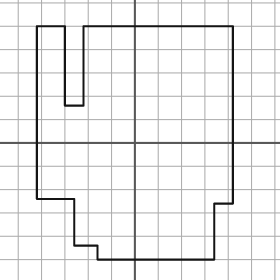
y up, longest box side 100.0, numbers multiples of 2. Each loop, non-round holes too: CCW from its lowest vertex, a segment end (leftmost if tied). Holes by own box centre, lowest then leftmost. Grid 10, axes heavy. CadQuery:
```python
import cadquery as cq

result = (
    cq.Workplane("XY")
    .moveTo(-16.0, -50.0)
    .lineTo(34.0, -50.0)
    .lineTo(34.0, -26.0)
    .lineTo(42.0, -26.0)
    .lineTo(42.0, 50.0)
    .lineTo(-22.0, 50.0)
    .lineTo(-22.0, 16.0)
    .lineTo(-30.0, 16.0)
    .lineTo(-30.0, 50.0)
    .lineTo(-42.0, 50.0)
    .lineTo(-42.0, -24.0)
    .lineTo(-26.0, -24.0)
    .lineTo(-26.0, -44.0)
    .lineTo(-16.0, -44.0)
    .close()
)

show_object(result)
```